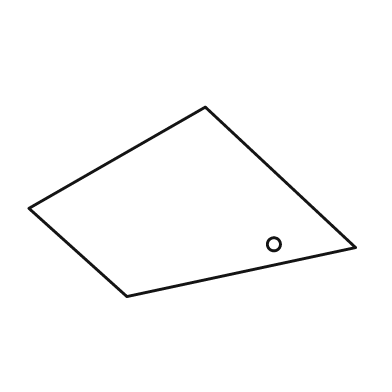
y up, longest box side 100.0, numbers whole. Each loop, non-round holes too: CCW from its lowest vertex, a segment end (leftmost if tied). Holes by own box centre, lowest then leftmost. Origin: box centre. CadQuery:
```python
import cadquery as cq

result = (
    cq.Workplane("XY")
    .moveTo(-20.0, -29.0)
    .lineTo(50.0, -14.0)
    .lineTo(4.0, 29.0)
    .lineTo(-50.0, -2.0)
    .close()
    .moveTo(25.0, -13.0)
    .circle(2.0)
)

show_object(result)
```